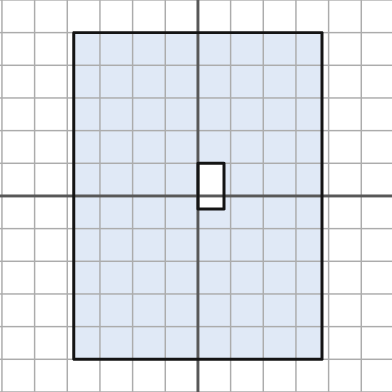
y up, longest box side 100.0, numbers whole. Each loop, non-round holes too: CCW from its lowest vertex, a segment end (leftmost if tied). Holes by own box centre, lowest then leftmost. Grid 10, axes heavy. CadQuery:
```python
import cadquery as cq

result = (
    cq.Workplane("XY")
    .moveTo(-38.0, -50.0)
    .lineTo(38.0, -50.0)
    .lineTo(38.0, 50.0)
    .lineTo(-38.0, 50.0)
    .close()
    .moveTo(0.0, -4.0)
    .lineTo(8.0, -4.0)
    .lineTo(8.0, 10.0)
    .lineTo(0.0, 10.0)
    .close()
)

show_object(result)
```